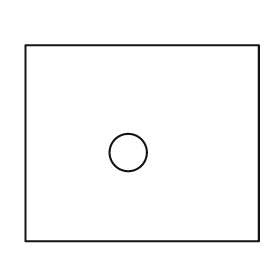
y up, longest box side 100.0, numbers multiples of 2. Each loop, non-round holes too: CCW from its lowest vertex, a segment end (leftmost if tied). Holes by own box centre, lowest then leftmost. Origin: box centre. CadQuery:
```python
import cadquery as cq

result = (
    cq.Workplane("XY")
    .moveTo(-50.0, -42.0)
    .lineTo(50.0, -42.0)
    .lineTo(50.0, 42.0)
    .lineTo(-50.0, 42.0)
    .close()
    .moveTo(-6.0, -4.0)
    .circle(8.0)
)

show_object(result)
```